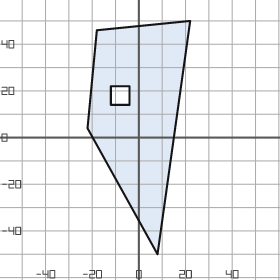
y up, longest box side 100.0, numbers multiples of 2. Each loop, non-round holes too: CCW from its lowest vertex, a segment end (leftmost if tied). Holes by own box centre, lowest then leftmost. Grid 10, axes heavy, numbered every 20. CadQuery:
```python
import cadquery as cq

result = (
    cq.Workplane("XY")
    .moveTo(8.0, -50.0)
    .lineTo(22.0, 50.0)
    .lineTo(-18.0, 46.0)
    .lineTo(-22.0, 4.0)
    .close()
    .moveTo(-12.0, 14.0)
    .lineTo(-4.0, 14.0)
    .lineTo(-4.0, 22.0)
    .lineTo(-12.0, 22.0)
    .close()
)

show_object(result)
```